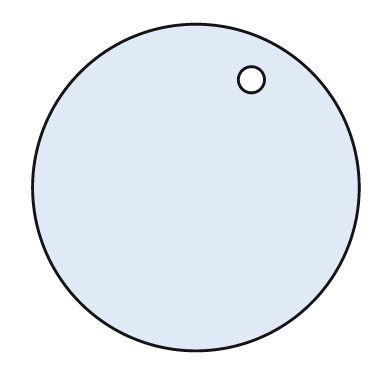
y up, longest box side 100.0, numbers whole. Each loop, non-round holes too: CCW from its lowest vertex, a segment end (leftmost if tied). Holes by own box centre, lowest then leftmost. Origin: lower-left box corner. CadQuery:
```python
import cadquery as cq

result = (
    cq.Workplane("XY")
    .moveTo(50.0, 50.0)
    .circle(50.0)
    .moveTo(67.0, 83.0)
    .circle(4.0)
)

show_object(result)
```